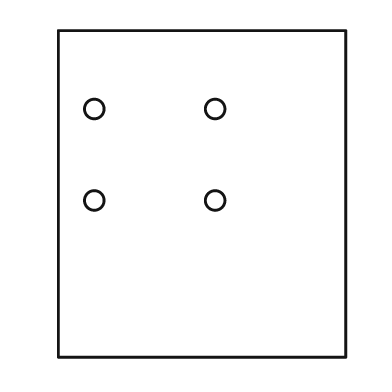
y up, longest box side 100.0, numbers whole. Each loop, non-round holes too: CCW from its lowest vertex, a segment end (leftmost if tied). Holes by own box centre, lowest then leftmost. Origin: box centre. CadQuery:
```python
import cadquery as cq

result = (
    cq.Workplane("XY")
    .moveTo(-44.0, -50.0)
    .lineTo(44.0, -50.0)
    .lineTo(44.0, 50.0)
    .lineTo(-44.0, 50.0)
    .close()
    .moveTo(-33.0, -2.0)
    .circle(3.0)
    .moveTo(4.0, -2.0)
    .circle(3.0)
    .moveTo(-33.0, 26.0)
    .circle(3.0)
    .moveTo(4.0, 26.0)
    .circle(3.0)
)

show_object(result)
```